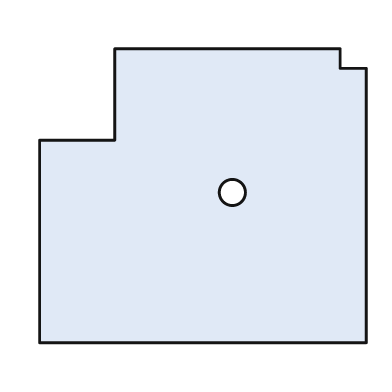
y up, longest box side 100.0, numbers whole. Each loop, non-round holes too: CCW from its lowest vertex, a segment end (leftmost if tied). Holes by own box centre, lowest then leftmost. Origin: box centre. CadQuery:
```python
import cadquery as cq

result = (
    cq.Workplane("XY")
    .moveTo(-50.0, -45.0)
    .lineTo(50.0, -45.0)
    .lineTo(50.0, 39.0)
    .lineTo(42.0, 39.0)
    .lineTo(42.0, 45.0)
    .lineTo(-27.0, 45.0)
    .lineTo(-27.0, 17.0)
    .lineTo(-50.0, 17.0)
    .close()
    .moveTo(9.0, 1.0)
    .circle(4.0)
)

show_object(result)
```